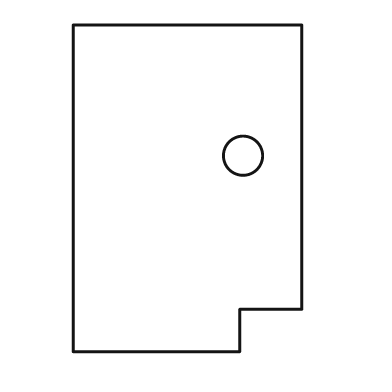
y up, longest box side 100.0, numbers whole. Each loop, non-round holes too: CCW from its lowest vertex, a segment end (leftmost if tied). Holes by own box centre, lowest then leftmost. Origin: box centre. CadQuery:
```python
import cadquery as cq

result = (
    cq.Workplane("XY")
    .moveTo(-35.0, -50.0)
    .lineTo(16.0, -50.0)
    .lineTo(16.0, -37.0)
    .lineTo(35.0, -37.0)
    .lineTo(35.0, 50.0)
    .lineTo(-35.0, 50.0)
    .close()
    .moveTo(17.0, 10.0)
    .circle(6.0)
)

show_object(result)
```